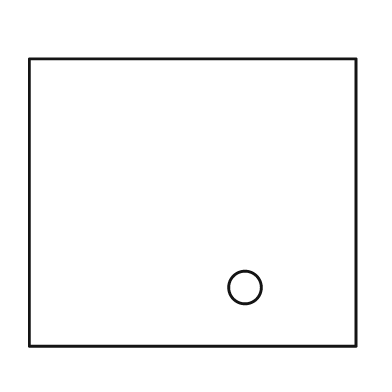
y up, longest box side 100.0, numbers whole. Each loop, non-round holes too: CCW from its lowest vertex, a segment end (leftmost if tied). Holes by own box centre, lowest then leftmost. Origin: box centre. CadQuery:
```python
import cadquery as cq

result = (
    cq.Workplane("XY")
    .moveTo(-50.0, -44.0)
    .lineTo(50.0, -44.0)
    .lineTo(50.0, 44.0)
    .lineTo(-50.0, 44.0)
    .close()
    .moveTo(16.0, -26.0)
    .circle(5.0)
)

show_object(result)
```